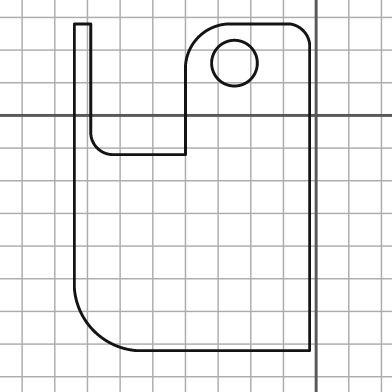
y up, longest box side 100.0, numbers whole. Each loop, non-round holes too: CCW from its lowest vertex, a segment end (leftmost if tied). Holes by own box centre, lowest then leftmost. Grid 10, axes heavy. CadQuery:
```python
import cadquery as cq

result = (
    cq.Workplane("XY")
    .moveTo(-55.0, -72.0)
    .lineTo(-2.0, -72.0)
    .lineTo(-2.0, 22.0)
    .threePointArc((-4.0, 26.0), (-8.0, 28.0))
    .lineTo(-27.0, 28.0)
    .threePointArc((-36.0, 24.0), (-40.0, 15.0))
    .lineTo(-40.0, -12.0)
    .lineTo(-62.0, -12.0)
    .threePointArc((-67.0, -10.0), (-69.0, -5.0))
    .lineTo(-69.0, 28.0)
    .lineTo(-74.0, 28.0)
    .lineTo(-74.0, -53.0)
    .threePointArc((-68.0, -66.0), (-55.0, -72.0))
    .close()
    .moveTo(-25.0, 16.0)
    .circle(7.0)
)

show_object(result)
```